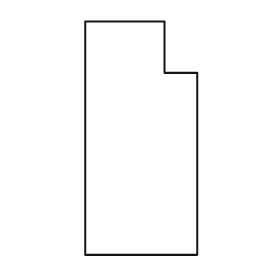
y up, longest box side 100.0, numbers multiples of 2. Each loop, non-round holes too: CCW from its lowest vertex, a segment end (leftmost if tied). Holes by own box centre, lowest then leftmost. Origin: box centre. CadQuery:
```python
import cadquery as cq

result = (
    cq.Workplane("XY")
    .moveTo(-24.0, -50.0)
    .lineTo(24.0, -50.0)
    .lineTo(24.0, 28.0)
    .lineTo(10.0, 28.0)
    .lineTo(10.0, 50.0)
    .lineTo(-24.0, 50.0)
    .close()
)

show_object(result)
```